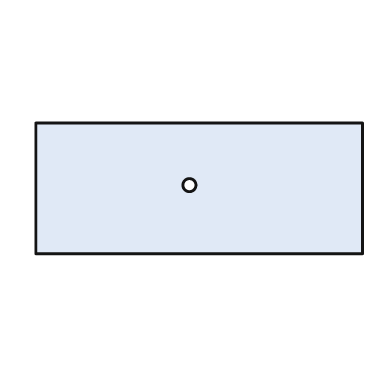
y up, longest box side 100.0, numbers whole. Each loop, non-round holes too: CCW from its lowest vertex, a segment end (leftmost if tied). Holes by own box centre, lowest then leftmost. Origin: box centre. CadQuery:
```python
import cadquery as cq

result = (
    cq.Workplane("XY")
    .moveTo(-50.0, -20.0)
    .lineTo(50.0, -20.0)
    .lineTo(50.0, 20.0)
    .lineTo(-50.0, 20.0)
    .close()
    .moveTo(-3.0, 1.0)
    .circle(2.0)
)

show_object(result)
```